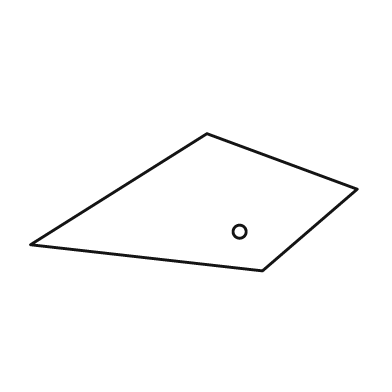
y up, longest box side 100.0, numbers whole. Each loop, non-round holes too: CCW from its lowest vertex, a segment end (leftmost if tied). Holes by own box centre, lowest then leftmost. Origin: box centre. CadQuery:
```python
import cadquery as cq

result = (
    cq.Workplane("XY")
    .moveTo(21.0, -21.0)
    .lineTo(50.0, 4.0)
    .lineTo(4.0, 21.0)
    .lineTo(-50.0, -13.0)
    .close()
    .moveTo(14.0, -9.0)
    .circle(2.0)
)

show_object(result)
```